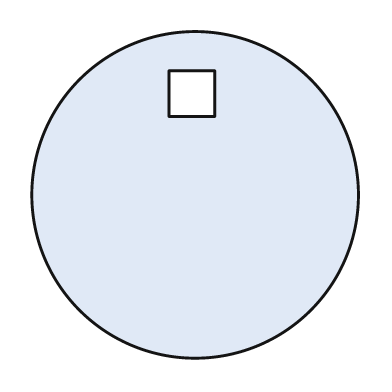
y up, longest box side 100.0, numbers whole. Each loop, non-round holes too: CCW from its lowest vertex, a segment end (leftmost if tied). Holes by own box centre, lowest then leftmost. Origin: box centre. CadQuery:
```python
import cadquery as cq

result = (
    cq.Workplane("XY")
    .moveTo(0.0, 0.0)
    .circle(50.0)
    .moveTo(-8.0, 24.0)
    .lineTo(6.0, 24.0)
    .lineTo(6.0, 38.0)
    .lineTo(-8.0, 38.0)
    .close()
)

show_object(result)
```